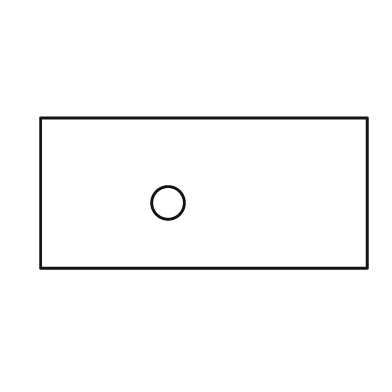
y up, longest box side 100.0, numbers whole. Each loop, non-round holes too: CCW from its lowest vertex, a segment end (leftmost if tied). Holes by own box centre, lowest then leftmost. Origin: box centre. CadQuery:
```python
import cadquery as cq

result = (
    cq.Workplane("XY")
    .moveTo(-50.0, -23.0)
    .lineTo(50.0, -23.0)
    .lineTo(50.0, 23.0)
    .lineTo(-50.0, 23.0)
    .close()
    .moveTo(-11.0, -3.0)
    .circle(5.0)
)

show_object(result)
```